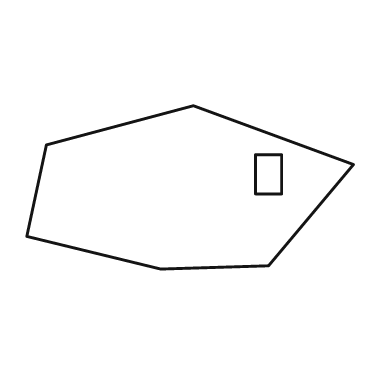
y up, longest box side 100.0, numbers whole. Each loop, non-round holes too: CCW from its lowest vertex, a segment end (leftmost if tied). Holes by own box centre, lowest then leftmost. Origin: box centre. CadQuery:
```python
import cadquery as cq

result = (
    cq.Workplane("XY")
    .moveTo(-9.0, -25.0)
    .lineTo(24.0, -24.0)
    .lineTo(50.0, 7.0)
    .lineTo(1.0, 25.0)
    .lineTo(-44.0, 13.0)
    .lineTo(-50.0, -15.0)
    .close()
    .moveTo(20.0, -2.0)
    .lineTo(28.0, -2.0)
    .lineTo(28.0, 10.0)
    .lineTo(20.0, 10.0)
    .close()
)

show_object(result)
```